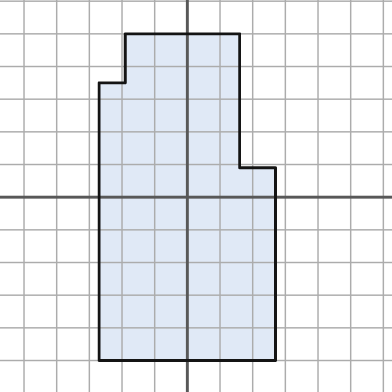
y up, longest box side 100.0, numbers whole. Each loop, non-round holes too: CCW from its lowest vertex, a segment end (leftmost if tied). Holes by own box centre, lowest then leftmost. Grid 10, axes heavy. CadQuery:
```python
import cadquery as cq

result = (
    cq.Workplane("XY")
    .moveTo(-27.0, -50.0)
    .lineTo(27.0, -50.0)
    .lineTo(27.0, 9.0)
    .lineTo(16.0, 9.0)
    .lineTo(16.0, 50.0)
    .lineTo(-19.0, 50.0)
    .lineTo(-19.0, 35.0)
    .lineTo(-27.0, 35.0)
    .close()
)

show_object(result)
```